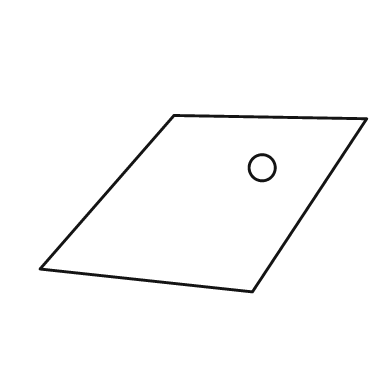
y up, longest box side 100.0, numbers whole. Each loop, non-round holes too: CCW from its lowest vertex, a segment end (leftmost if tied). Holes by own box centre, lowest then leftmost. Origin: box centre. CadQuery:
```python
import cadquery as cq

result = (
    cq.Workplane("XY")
    .moveTo(15.0, -27.0)
    .lineTo(50.0, 26.0)
    .lineTo(-9.0, 27.0)
    .lineTo(-50.0, -20.0)
    .close()
    .moveTo(18.0, 11.0)
    .circle(4.0)
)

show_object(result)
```